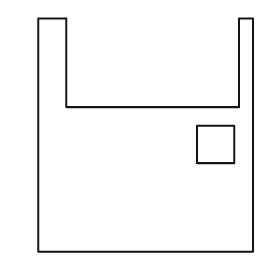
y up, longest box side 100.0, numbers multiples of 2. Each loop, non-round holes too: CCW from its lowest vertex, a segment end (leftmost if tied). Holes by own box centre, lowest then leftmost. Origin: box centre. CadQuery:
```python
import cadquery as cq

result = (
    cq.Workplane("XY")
    .moveTo(-46.0, -50.0)
    .lineTo(46.0, -50.0)
    .lineTo(46.0, 50.0)
    .lineTo(40.0, 50.0)
    .lineTo(40.0, 12.0)
    .lineTo(-34.0, 12.0)
    .lineTo(-34.0, 50.0)
    .lineTo(-46.0, 50.0)
    .close()
    .moveTo(22.0, -12.0)
    .lineTo(38.0, -12.0)
    .lineTo(38.0, 4.0)
    .lineTo(22.0, 4.0)
    .close()
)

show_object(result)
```